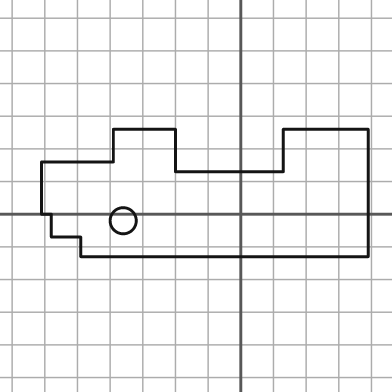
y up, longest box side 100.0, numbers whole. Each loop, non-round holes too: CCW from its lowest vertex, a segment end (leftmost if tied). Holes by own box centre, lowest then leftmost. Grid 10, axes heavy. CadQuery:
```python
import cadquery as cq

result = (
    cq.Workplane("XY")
    .moveTo(-49.0, -13.0)
    .lineTo(39.0, -13.0)
    .lineTo(39.0, 26.0)
    .lineTo(13.0, 26.0)
    .lineTo(13.0, 13.0)
    .lineTo(-20.0, 13.0)
    .lineTo(-20.0, 26.0)
    .lineTo(-39.0, 26.0)
    .lineTo(-39.0, 16.0)
    .lineTo(-61.0, 16.0)
    .lineTo(-61.0, 0.0)
    .lineTo(-58.0, 0.0)
    .lineTo(-58.0, -7.0)
    .lineTo(-49.0, -7.0)
    .close()
    .moveTo(-36.0, -2.0)
    .circle(4.0)
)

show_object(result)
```